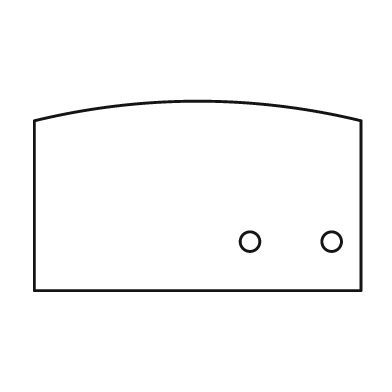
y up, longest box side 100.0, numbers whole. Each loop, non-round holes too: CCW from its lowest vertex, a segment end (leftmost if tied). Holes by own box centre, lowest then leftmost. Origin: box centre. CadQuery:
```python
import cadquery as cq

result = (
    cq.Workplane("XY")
    .moveTo(-50.0, -29.0)
    .lineTo(50.0, -29.0)
    .lineTo(50.0, 23.0)
    .threePointArc((0.0, 29.0), (-50.0, 23.0))
    .close()
    .moveTo(16.0, -14.0)
    .circle(3.0)
    .moveTo(41.0, -14.0)
    .circle(3.0)
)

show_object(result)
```